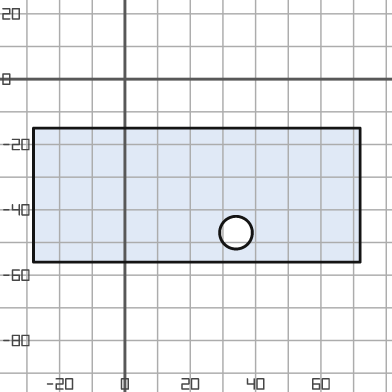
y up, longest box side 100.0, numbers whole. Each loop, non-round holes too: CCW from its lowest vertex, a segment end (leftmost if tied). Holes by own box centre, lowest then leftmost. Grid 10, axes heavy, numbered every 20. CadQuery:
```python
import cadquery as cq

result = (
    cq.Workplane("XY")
    .moveTo(-28.0, -56.0)
    .lineTo(72.0, -56.0)
    .lineTo(72.0, -15.0)
    .lineTo(-28.0, -15.0)
    .close()
    .moveTo(34.0, -47.0)
    .circle(5.0)
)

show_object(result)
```